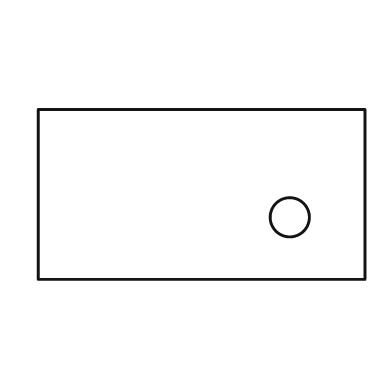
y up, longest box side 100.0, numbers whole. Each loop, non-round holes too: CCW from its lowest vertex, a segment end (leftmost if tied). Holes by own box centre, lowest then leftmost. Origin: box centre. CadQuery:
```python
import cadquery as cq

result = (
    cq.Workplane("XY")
    .moveTo(-50.0, -26.0)
    .lineTo(50.0, -26.0)
    .lineTo(50.0, 26.0)
    .lineTo(-50.0, 26.0)
    .close()
    .moveTo(27.0, -7.0)
    .circle(6.0)
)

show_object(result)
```